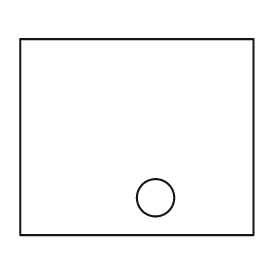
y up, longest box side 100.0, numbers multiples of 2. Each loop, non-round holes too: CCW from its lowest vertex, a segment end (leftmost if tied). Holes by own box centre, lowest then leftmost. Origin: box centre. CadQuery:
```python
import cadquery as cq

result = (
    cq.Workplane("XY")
    .moveTo(-50.0, -42.0)
    .lineTo(50.0, -42.0)
    .lineTo(50.0, 42.0)
    .lineTo(-50.0, 42.0)
    .close()
    .moveTo(8.0, -26.0)
    .circle(8.0)
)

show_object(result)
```